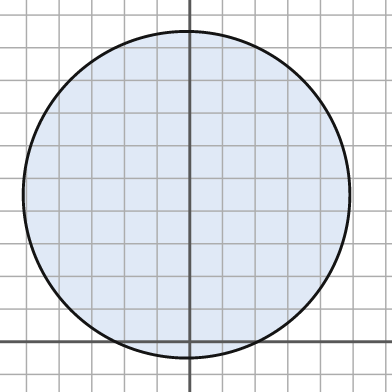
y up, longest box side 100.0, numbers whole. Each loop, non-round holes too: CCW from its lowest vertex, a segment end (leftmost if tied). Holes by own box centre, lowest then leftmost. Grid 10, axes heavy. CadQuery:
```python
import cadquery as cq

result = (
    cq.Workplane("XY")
    .moveTo(-1.0, 45.0)
    .circle(50.0)
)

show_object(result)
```